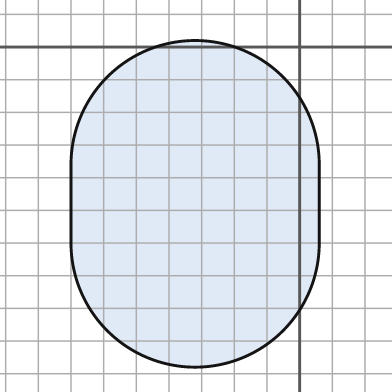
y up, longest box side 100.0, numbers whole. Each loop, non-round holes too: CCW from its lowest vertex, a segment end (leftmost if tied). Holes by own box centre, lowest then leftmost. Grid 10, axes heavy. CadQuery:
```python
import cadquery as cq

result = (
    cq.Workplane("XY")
    .moveTo(-70.0, -60.0)
    .threePointArc((-32.0, -98.0), (6.0, -60.0))
    .lineTo(6.0, -36.0)
    .threePointArc((-32.0, 2.0), (-70.0, -36.0))
    .close()
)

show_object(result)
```